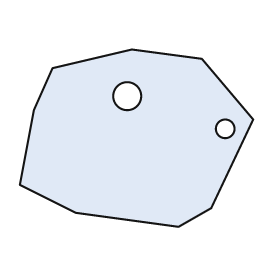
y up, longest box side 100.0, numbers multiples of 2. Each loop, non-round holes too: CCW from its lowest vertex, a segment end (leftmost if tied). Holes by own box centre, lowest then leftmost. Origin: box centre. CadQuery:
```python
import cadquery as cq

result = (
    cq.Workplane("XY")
    .moveTo(18.0, -38.0)
    .lineTo(32.0, -30.0)
    .lineTo(50.0, 8.0)
    .lineTo(28.0, 34.0)
    .lineTo(-2.0, 38.0)
    .lineTo(-36.0, 30.0)
    .lineTo(-44.0, 12.0)
    .lineTo(-50.0, -20.0)
    .lineTo(-26.0, -32.0)
    .close()
    .moveTo(38.0, 4.0)
    .circle(4.0)
    .moveTo(-4.0, 18.0)
    .circle(6.0)
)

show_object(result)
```